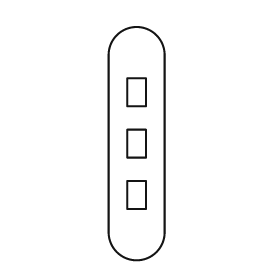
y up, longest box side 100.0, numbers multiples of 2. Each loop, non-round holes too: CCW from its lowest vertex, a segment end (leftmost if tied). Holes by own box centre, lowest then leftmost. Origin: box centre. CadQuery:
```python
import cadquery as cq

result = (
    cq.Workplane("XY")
    .moveTo(-12.0, -38.0)
    .threePointArc((0.0, -50.0), (12.0, -38.0))
    .lineTo(12.0, 38.0)
    .threePointArc((0.0, 50.0), (-12.0, 38.0))
    .close()
    .moveTo(-4.0, -28.0)
    .lineTo(4.0, -28.0)
    .lineTo(4.0, -16.0)
    .lineTo(-4.0, -16.0)
    .close()
    .moveTo(-4.0, -6.0)
    .lineTo(4.0, -6.0)
    .lineTo(4.0, 6.0)
    .lineTo(-4.0, 6.0)
    .close()
    .moveTo(-4.0, 16.0)
    .lineTo(4.0, 16.0)
    .lineTo(4.0, 28.0)
    .lineTo(-4.0, 28.0)
    .close()
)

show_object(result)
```